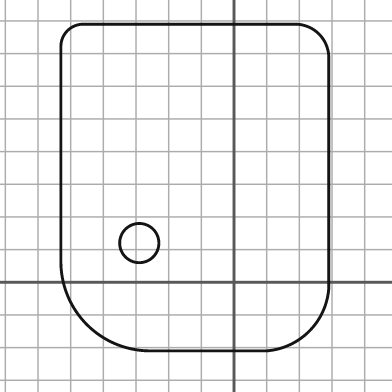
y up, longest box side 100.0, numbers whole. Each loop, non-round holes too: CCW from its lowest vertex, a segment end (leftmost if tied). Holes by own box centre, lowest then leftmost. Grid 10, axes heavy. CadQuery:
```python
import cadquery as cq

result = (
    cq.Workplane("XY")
    .moveTo(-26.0, -21.0)
    .lineTo(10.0, -21.0)
    .threePointArc((23.0, -15.0), (29.0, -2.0))
    .lineTo(29.0, 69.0)
    .threePointArc((26.0, 76.0), (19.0, 79.0))
    .lineTo(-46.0, 79.0)
    .threePointArc((-51.0, 77.0), (-53.0, 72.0))
    .lineTo(-53.0, 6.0)
    .threePointArc((-45.0, -13.0), (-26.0, -21.0))
    .close()
    .moveTo(-29.0, 12.0)
    .circle(6.0)
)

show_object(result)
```